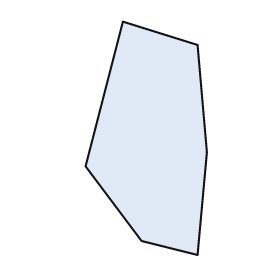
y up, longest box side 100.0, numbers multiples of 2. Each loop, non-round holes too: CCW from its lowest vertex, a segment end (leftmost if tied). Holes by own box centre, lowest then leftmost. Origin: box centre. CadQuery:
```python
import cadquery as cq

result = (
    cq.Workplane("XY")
    .moveTo(22.0, -50.0)
    .lineTo(26.0, -6.0)
    .lineTo(22.0, 40.0)
    .lineTo(-10.0, 50.0)
    .lineTo(-26.0, -12.0)
    .lineTo(-2.0, -44.0)
    .close()
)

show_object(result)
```